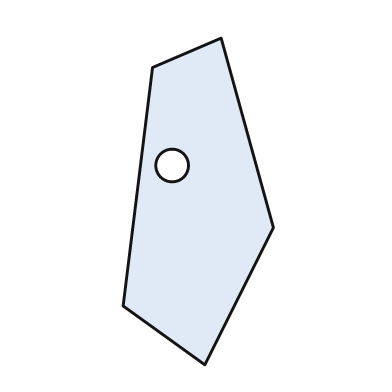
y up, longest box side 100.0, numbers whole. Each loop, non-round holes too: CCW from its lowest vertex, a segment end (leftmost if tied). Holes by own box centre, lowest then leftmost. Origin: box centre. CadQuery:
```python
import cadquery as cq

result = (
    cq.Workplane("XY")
    .moveTo(2.0, -50.0)
    .lineTo(23.0, -8.0)
    .lineTo(7.0, 50.0)
    .lineTo(-14.0, 41.0)
    .lineTo(-23.0, -32.0)
    .close()
    .moveTo(-8.0, 11.0)
    .circle(5.0)
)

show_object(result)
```